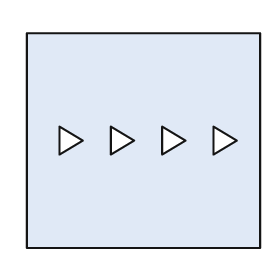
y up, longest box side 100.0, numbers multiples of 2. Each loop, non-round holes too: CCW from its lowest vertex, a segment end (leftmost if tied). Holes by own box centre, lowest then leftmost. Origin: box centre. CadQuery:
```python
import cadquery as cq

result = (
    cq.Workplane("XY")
    .moveTo(-50.0, -46.0)
    .lineTo(50.0, -46.0)
    .lineTo(50.0, 46.0)
    .lineTo(-50.0, 46.0)
    .close()
    .moveTo(-36.0, -6.0)
    .lineTo(-26.0, 0.0)
    .lineTo(-36.0, 6.0)
    .close()
    .moveTo(-14.0, -6.0)
    .lineTo(-4.0, 0.0)
    .lineTo(-14.0, 6.0)
    .close()
    .moveTo(8.0, -6.0)
    .lineTo(18.0, 0.0)
    .lineTo(8.0, 6.0)
    .close()
    .moveTo(30.0, -6.0)
    .lineTo(40.0, 0.0)
    .lineTo(30.0, 6.0)
    .close()
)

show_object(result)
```